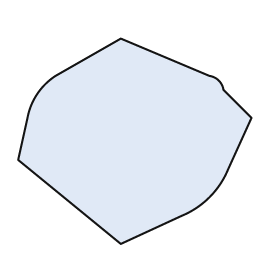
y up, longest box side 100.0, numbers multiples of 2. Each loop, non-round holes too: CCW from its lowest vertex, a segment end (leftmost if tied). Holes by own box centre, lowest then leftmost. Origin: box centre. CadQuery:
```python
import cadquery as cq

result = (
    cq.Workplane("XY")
    .moveTo(-6.0, -44.0)
    .lineTo(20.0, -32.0)
    .threePointArc((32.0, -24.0), (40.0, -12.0))
    .lineTo(50.0, 10.0)
    .lineTo(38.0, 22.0)
    .threePointArc((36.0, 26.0), (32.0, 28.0))
    .lineTo(-6.0, 44.0)
    .lineTo(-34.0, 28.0)
    .threePointArc((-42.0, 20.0), (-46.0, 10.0))
    .lineTo(-50.0, -8.0)
    .close()
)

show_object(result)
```